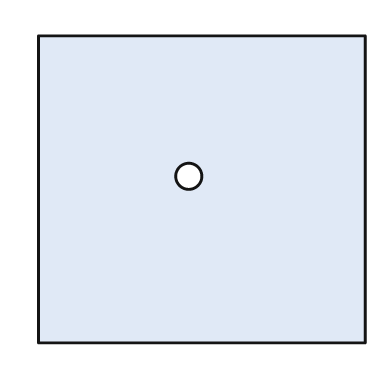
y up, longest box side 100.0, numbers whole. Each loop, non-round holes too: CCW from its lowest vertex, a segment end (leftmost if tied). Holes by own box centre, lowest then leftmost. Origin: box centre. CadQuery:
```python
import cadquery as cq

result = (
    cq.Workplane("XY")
    .moveTo(-50.0, -47.0)
    .lineTo(50.0, -47.0)
    .lineTo(50.0, 47.0)
    .lineTo(-50.0, 47.0)
    .close()
    .moveTo(-4.0, 4.0)
    .circle(4.0)
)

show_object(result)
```